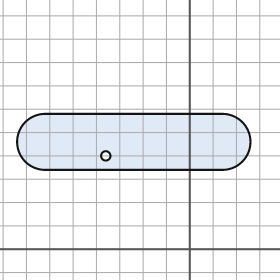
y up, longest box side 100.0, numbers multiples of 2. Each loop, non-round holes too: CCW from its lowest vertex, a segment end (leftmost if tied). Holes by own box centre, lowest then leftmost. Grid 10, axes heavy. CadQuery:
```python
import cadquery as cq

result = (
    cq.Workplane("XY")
    .moveTo(-62.0, 34.0)
    .lineTo(14.0, 34.0)
    .threePointArc((26.0, 46.0), (14.0, 58.0))
    .lineTo(-62.0, 58.0)
    .threePointArc((-74.0, 46.0), (-62.0, 34.0))
    .close()
    .moveTo(-36.0, 40.0)
    .circle(2.0)
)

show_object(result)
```